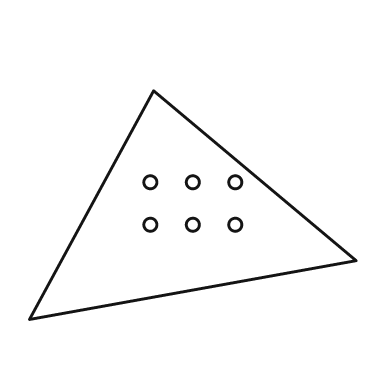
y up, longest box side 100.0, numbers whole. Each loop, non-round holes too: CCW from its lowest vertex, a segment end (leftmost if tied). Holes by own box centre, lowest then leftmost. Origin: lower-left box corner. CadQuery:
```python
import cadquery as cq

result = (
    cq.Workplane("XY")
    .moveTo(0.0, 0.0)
    .lineTo(100.0, 18.0)
    .lineTo(38.0, 70.0)
    .close()
    .moveTo(37.0, 29.0)
    .circle(2.0)
    .moveTo(50.0, 29.0)
    .circle(2.0)
    .moveTo(63.0, 29.0)
    .circle(2.0)
    .moveTo(37.0, 42.0)
    .circle(2.0)
    .moveTo(50.0, 42.0)
    .circle(2.0)
    .moveTo(63.0, 42.0)
    .circle(2.0)
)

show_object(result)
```